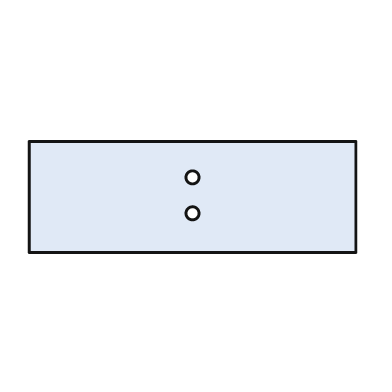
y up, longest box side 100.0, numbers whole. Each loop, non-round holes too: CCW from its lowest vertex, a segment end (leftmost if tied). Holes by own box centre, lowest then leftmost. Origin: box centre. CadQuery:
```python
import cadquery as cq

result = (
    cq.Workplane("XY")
    .moveTo(-50.0, -17.0)
    .lineTo(50.0, -17.0)
    .lineTo(50.0, 17.0)
    .lineTo(-50.0, 17.0)
    .close()
    .moveTo(0.0, -5.0)
    .circle(2.0)
    .moveTo(0.0, 6.0)
    .circle(2.0)
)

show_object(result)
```